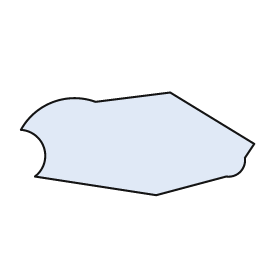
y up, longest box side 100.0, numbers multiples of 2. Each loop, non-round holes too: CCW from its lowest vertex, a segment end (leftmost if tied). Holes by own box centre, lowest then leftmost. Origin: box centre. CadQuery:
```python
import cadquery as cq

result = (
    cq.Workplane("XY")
    .moveTo(8.0, -22.0)
    .lineTo(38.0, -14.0)
    .threePointArc((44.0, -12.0), (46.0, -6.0))
    .lineTo(50.0, 0.0)
    .lineTo(14.0, 22.0)
    .lineTo(-18.0, 18.0)
    .threePointArc((-36.0, 18.0), (-50.0, 6.0))
    .threePointArc((-40.0, -2.0), (-44.0, -14.0))
    .close()
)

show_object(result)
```